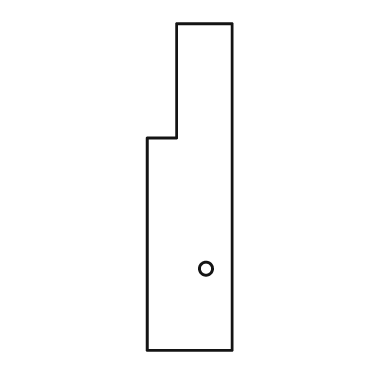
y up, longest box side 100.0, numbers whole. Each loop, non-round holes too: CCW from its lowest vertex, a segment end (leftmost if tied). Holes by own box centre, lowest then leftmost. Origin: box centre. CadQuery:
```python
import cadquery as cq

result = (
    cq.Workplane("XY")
    .moveTo(-13.0, -50.0)
    .lineTo(13.0, -50.0)
    .lineTo(13.0, 50.0)
    .lineTo(-4.0, 50.0)
    .lineTo(-4.0, 15.0)
    .lineTo(-13.0, 15.0)
    .close()
    .moveTo(5.0, -25.0)
    .circle(2.0)
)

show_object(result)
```